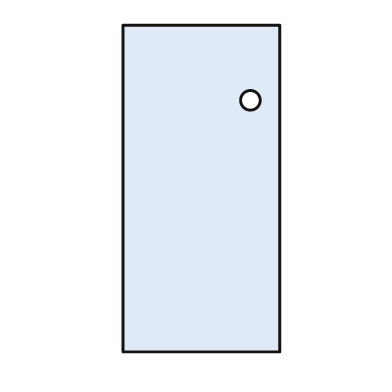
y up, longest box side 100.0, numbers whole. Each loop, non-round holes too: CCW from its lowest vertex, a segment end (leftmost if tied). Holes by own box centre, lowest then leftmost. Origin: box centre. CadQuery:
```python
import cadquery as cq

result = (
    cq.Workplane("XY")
    .moveTo(-24.0, -50.0)
    .lineTo(24.0, -50.0)
    .lineTo(24.0, 50.0)
    .lineTo(-24.0, 50.0)
    .close()
    .moveTo(15.0, 27.0)
    .circle(3.0)
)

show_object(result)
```